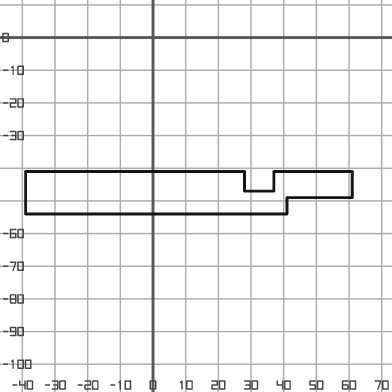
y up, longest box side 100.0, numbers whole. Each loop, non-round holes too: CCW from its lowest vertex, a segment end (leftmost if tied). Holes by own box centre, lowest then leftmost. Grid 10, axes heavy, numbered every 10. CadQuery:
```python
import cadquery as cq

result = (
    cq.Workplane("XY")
    .moveTo(-39.0, -54.0)
    .lineTo(41.0, -54.0)
    .lineTo(41.0, -49.0)
    .lineTo(61.0, -49.0)
    .lineTo(61.0, -41.0)
    .lineTo(37.0, -41.0)
    .lineTo(37.0, -47.0)
    .lineTo(28.0, -47.0)
    .lineTo(28.0, -41.0)
    .lineTo(-39.0, -41.0)
    .close()
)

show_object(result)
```